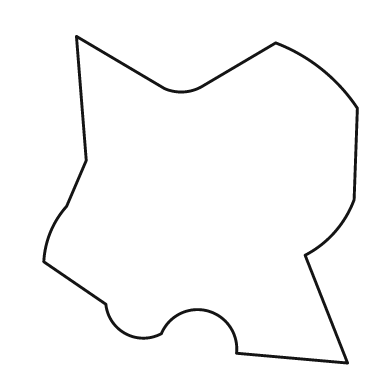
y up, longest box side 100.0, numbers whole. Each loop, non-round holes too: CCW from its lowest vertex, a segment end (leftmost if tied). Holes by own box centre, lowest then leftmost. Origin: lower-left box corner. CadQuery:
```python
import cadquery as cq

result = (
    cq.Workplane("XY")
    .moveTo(93.0, 0.0)
    .lineTo(80.0, 33.0)
    .threePointArc((89.0, 40.0), (95.0, 50.0))
    .lineTo(96.0, 78.0)
    .threePointArc((85.0, 90.0), (71.0, 98.0))
    .lineTo(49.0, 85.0)
    .threePointArc((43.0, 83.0), (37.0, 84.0))
    .lineTo(10.0, 100.0)
    .lineTo(13.0, 62.0)
    .lineTo(7.0, 48.0)
    .threePointArc((2.0, 40.0), (0.0, 31.0))
    .lineTo(19.0, 18.0)
    .threePointArc((25.0, 9.0), (36.0, 9.0))
    .threePointArc((50.0, 16.0), (59.0, 3.0))
    .close()
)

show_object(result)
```